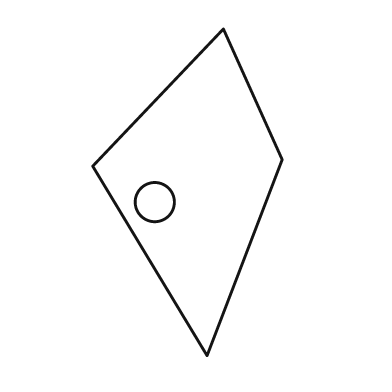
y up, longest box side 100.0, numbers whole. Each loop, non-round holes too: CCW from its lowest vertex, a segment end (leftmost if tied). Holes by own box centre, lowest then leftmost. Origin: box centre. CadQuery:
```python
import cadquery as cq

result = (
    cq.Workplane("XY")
    .moveTo(6.0, -50.0)
    .lineTo(29.0, 10.0)
    .lineTo(11.0, 50.0)
    .lineTo(-29.0, 8.0)
    .close()
    .moveTo(-10.0, -3.0)
    .circle(6.0)
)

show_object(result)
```